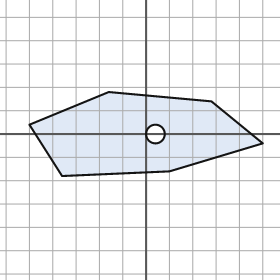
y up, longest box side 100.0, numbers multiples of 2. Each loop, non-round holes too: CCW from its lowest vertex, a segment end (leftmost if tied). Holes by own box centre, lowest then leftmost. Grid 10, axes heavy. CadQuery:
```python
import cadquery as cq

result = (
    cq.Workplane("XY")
    .moveTo(-36.0, -18.0)
    .lineTo(10.0, -16.0)
    .lineTo(50.0, -4.0)
    .lineTo(28.0, 14.0)
    .lineTo(-16.0, 18.0)
    .lineTo(-50.0, 4.0)
    .close()
    .moveTo(4.0, 0.0)
    .circle(4.0)
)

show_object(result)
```